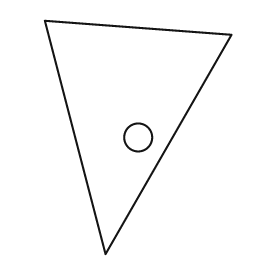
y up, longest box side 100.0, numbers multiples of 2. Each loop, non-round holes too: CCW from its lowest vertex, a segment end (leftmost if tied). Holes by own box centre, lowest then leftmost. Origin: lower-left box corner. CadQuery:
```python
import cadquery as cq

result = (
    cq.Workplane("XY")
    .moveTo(26.0, 0.0)
    .lineTo(80.0, 94.0)
    .lineTo(0.0, 100.0)
    .close()
    .moveTo(40.0, 50.0)
    .circle(6.0)
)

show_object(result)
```